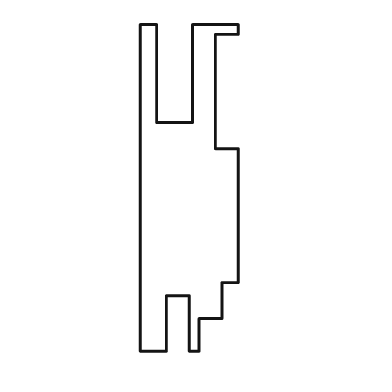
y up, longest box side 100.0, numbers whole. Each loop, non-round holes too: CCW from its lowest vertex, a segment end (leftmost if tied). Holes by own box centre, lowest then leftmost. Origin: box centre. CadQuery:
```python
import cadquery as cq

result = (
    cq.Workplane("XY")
    .moveTo(-15.0, -50.0)
    .lineTo(-7.0, -50.0)
    .lineTo(-7.0, -33.0)
    .lineTo(0.0, -33.0)
    .lineTo(0.0, -50.0)
    .lineTo(3.0, -50.0)
    .lineTo(3.0, -40.0)
    .lineTo(10.0, -40.0)
    .lineTo(10.0, -29.0)
    .lineTo(15.0, -29.0)
    .lineTo(15.0, 12.0)
    .lineTo(8.0, 12.0)
    .lineTo(8.0, 47.0)
    .lineTo(15.0, 47.0)
    .lineTo(15.0, 50.0)
    .lineTo(1.0, 50.0)
    .lineTo(1.0, 20.0)
    .lineTo(-10.0, 20.0)
    .lineTo(-10.0, 50.0)
    .lineTo(-15.0, 50.0)
    .close()
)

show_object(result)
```